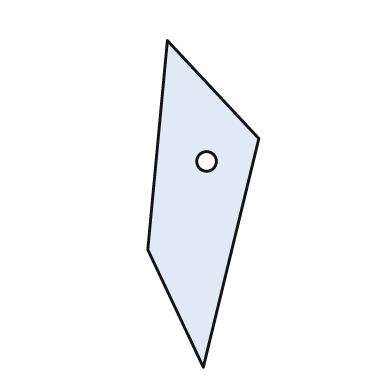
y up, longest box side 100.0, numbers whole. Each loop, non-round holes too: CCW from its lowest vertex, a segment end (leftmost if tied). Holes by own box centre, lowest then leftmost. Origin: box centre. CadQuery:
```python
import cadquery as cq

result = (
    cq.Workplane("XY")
    .moveTo(0.0, -50.0)
    .lineTo(17.0, 20.0)
    .lineTo(-11.0, 50.0)
    .lineTo(-17.0, -14.0)
    .close()
    .moveTo(1.0, 13.0)
    .circle(3.0)
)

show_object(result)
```